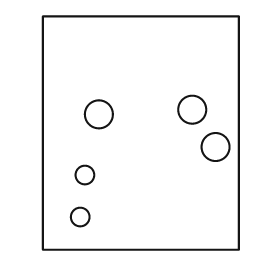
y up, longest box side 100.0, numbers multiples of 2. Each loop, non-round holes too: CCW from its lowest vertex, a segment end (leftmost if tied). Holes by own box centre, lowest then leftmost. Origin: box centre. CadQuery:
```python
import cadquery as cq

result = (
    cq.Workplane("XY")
    .moveTo(-42.0, -50.0)
    .lineTo(42.0, -50.0)
    .lineTo(42.0, 50.0)
    .lineTo(-42.0, 50.0)
    .close()
    .moveTo(-26.0, -36.0)
    .circle(4.0)
    .moveTo(-24.0, -18.0)
    .circle(4.0)
    .moveTo(32.0, -6.0)
    .circle(6.0)
    .moveTo(-18.0, 8.0)
    .circle(6.0)
    .moveTo(22.0, 10.0)
    .circle(6.0)
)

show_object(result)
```